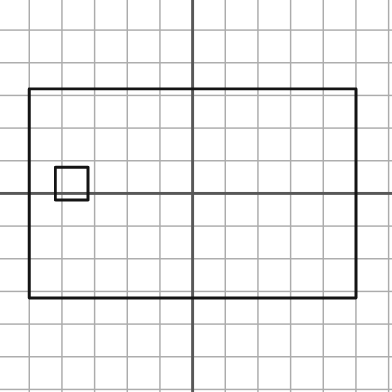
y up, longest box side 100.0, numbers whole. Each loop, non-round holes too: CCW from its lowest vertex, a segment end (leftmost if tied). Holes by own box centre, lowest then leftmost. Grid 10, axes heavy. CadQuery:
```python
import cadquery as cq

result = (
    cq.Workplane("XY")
    .moveTo(-50.0, -32.0)
    .lineTo(50.0, -32.0)
    .lineTo(50.0, 32.0)
    .lineTo(-50.0, 32.0)
    .close()
    .moveTo(-42.0, -2.0)
    .lineTo(-32.0, -2.0)
    .lineTo(-32.0, 8.0)
    .lineTo(-42.0, 8.0)
    .close()
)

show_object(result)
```